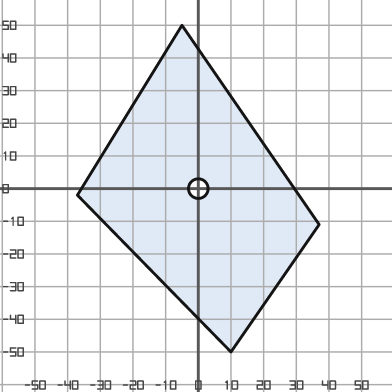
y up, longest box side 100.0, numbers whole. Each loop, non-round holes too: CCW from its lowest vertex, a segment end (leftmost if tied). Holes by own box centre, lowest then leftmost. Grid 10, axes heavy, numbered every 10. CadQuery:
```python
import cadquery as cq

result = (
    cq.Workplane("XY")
    .moveTo(10.0, -50.0)
    .lineTo(37.0, -11.0)
    .lineTo(-5.0, 50.0)
    .lineTo(-37.0, -2.0)
    .close()
    .moveTo(0.0, 0.0)
    .circle(3.0)
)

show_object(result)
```